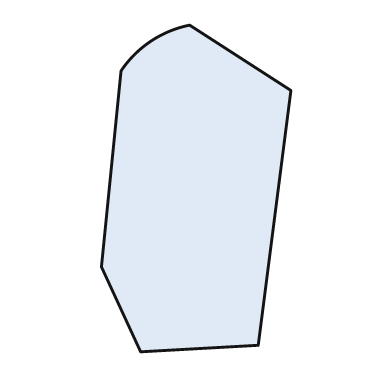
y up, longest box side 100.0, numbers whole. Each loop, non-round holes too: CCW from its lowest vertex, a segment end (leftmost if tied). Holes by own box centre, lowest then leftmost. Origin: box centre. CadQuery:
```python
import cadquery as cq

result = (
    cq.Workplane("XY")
    .moveTo(-17.0, -50.0)
    .lineTo(19.0, -48.0)
    .lineTo(29.0, 30.0)
    .lineTo(-2.0, 50.0)
    .threePointArc((-14.0, 45.0), (-23.0, 36.0))
    .lineTo(-29.0, -24.0)
    .close()
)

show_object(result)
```